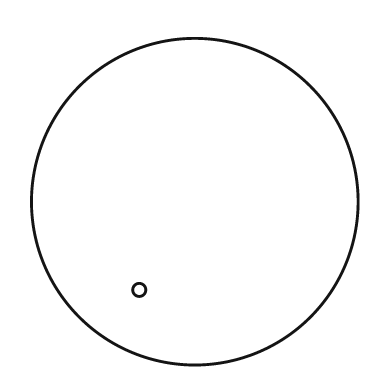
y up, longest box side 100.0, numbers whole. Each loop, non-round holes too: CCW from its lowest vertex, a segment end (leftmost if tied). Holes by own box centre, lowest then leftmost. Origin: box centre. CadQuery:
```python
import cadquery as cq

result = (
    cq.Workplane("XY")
    .moveTo(0.0, 0.0)
    .circle(50.0)
    .moveTo(-17.0, -27.0)
    .circle(2.0)
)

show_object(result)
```